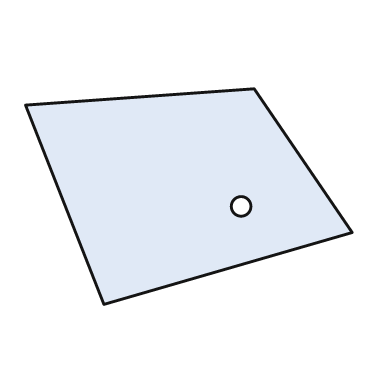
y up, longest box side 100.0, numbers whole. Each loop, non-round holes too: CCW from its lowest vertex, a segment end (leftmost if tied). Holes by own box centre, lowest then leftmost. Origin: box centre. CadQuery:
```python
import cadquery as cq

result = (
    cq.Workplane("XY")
    .moveTo(-26.0, -33.0)
    .lineTo(50.0, -11.0)
    .lineTo(20.0, 33.0)
    .lineTo(-50.0, 28.0)
    .close()
    .moveTo(16.0, -3.0)
    .circle(3.0)
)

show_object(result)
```